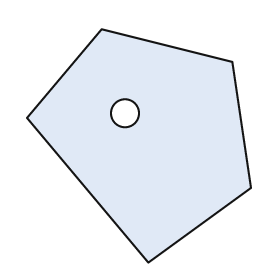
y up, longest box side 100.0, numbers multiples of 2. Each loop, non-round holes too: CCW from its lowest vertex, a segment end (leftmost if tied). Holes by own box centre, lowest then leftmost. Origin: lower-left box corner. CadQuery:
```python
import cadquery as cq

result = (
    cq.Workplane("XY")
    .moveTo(52.0, 0.0)
    .lineTo(96.0, 32.0)
    .lineTo(88.0, 86.0)
    .lineTo(32.0, 100.0)
    .lineTo(0.0, 62.0)
    .close()
    .moveTo(42.0, 64.0)
    .circle(6.0)
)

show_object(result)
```